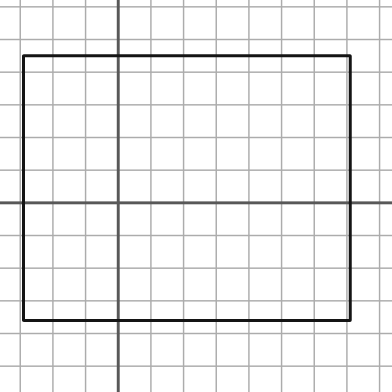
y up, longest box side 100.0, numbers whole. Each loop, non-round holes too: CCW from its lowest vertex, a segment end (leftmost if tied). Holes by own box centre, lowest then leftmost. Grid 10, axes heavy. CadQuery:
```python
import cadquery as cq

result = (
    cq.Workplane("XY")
    .moveTo(-29.0, -36.0)
    .lineTo(71.0, -36.0)
    .lineTo(71.0, 45.0)
    .lineTo(-29.0, 45.0)
    .close()
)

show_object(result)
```